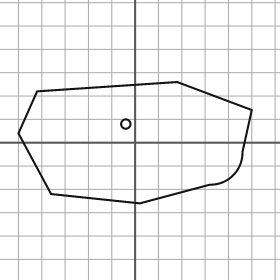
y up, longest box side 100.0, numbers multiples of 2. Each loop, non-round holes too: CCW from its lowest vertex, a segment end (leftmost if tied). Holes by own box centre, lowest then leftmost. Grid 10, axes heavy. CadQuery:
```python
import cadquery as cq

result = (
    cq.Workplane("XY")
    .moveTo(2.0, -26.0)
    .lineTo(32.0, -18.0)
    .threePointArc((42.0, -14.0), (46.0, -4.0))
    .lineTo(50.0, 14.0)
    .lineTo(18.0, 26.0)
    .lineTo(-42.0, 22.0)
    .lineTo(-50.0, 4.0)
    .lineTo(-36.0, -22.0)
    .close()
    .moveTo(-4.0, 8.0)
    .circle(2.0)
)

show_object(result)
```